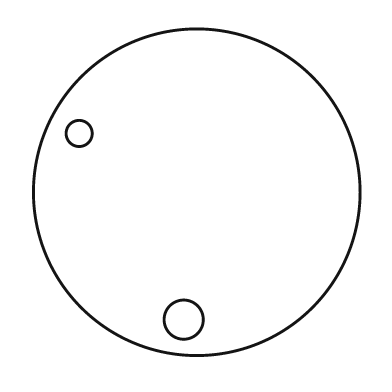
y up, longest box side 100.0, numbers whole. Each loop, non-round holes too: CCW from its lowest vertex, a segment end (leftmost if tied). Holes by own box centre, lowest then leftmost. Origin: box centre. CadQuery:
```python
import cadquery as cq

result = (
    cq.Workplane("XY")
    .moveTo(0.0, 0.0)
    .circle(50.0)
    .moveTo(-4.0, -39.0)
    .circle(6.0)
    .moveTo(-36.0, 18.0)
    .circle(4.0)
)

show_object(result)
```